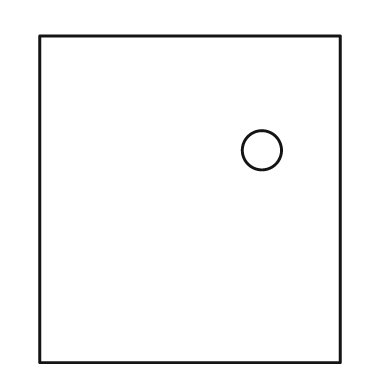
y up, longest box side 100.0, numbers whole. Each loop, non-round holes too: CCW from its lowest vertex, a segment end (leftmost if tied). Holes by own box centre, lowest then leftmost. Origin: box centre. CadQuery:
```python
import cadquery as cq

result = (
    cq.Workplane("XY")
    .moveTo(-46.0, -50.0)
    .lineTo(46.0, -50.0)
    .lineTo(46.0, 50.0)
    .lineTo(-46.0, 50.0)
    .close()
    .moveTo(22.0, 15.0)
    .circle(6.0)
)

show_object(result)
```